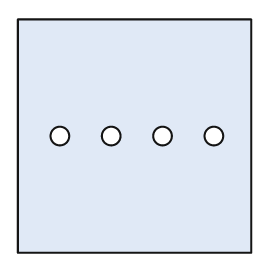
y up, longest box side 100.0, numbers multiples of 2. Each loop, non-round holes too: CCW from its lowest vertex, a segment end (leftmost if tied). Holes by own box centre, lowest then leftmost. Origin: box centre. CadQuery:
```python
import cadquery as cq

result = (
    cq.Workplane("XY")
    .moveTo(-50.0, -50.0)
    .lineTo(50.0, -50.0)
    .lineTo(50.0, 50.0)
    .lineTo(-50.0, 50.0)
    .close()
    .moveTo(-32.0, 0.0)
    .circle(4.0)
    .moveTo(-10.0, 0.0)
    .circle(4.0)
    .moveTo(12.0, 0.0)
    .circle(4.0)
    .moveTo(34.0, 0.0)
    .circle(4.0)
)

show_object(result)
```